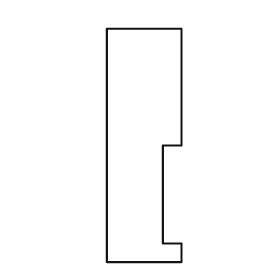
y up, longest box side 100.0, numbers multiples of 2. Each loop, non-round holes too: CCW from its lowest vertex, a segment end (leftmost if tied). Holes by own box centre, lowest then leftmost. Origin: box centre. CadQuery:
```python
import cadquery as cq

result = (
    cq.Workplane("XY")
    .moveTo(-16.0, -50.0)
    .lineTo(16.0, -50.0)
    .lineTo(16.0, -42.0)
    .lineTo(8.0, -42.0)
    .lineTo(8.0, 0.0)
    .lineTo(16.0, 0.0)
    .lineTo(16.0, 50.0)
    .lineTo(-16.0, 50.0)
    .close()
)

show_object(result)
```